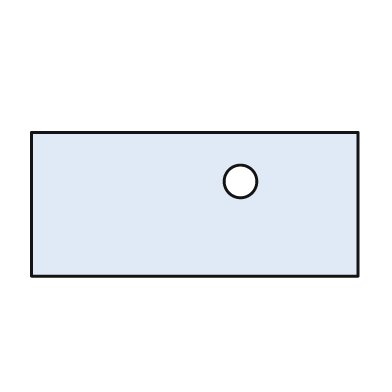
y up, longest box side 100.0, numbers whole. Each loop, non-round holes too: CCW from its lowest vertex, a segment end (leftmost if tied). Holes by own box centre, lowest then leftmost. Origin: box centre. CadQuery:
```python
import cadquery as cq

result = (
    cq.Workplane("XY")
    .moveTo(-50.0, -22.0)
    .lineTo(50.0, -22.0)
    .lineTo(50.0, 22.0)
    .lineTo(-50.0, 22.0)
    .close()
    .moveTo(14.0, 7.0)
    .circle(5.0)
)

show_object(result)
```